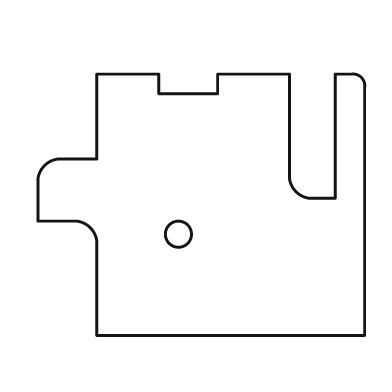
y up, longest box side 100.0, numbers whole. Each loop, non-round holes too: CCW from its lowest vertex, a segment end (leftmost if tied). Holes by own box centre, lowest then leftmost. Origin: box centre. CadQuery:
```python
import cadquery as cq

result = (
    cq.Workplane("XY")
    .moveTo(-32.0, -40.0)
    .lineTo(50.0, -40.0)
    .lineTo(50.0, 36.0)
    .threePointArc((49.0, 39.0), (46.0, 40.0))
    .lineTo(41.0, 40.0)
    .lineTo(41.0, 2.0)
    .lineTo(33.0, 2.0)
    .threePointArc((29.0, 4.0), (27.0, 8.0))
    .lineTo(27.0, 40.0)
    .lineTo(5.0, 40.0)
    .lineTo(5.0, 34.0)
    .lineTo(-13.0, 34.0)
    .lineTo(-13.0, 40.0)
    .lineTo(-32.0, 40.0)
    .lineTo(-32.0, 14.0)
    .lineTo(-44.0, 14.0)
    .threePointArc((-48.0, 12.0), (-50.0, 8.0))
    .lineTo(-50.0, -5.0)
    .lineTo(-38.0, -5.0)
    .threePointArc((-34.0, -7.0), (-32.0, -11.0))
    .close()
    .moveTo(-7.0, -9.0)
    .circle(4.0)
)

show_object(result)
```